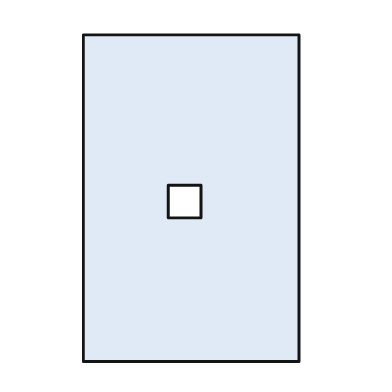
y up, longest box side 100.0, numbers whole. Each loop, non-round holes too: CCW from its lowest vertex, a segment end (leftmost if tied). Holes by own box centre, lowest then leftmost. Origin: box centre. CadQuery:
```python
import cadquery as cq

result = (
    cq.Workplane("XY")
    .moveTo(-33.0, -50.0)
    .lineTo(33.0, -50.0)
    .lineTo(33.0, 50.0)
    .lineTo(-33.0, 50.0)
    .close()
    .moveTo(-7.0, -6.0)
    .lineTo(3.0, -6.0)
    .lineTo(3.0, 4.0)
    .lineTo(-7.0, 4.0)
    .close()
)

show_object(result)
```